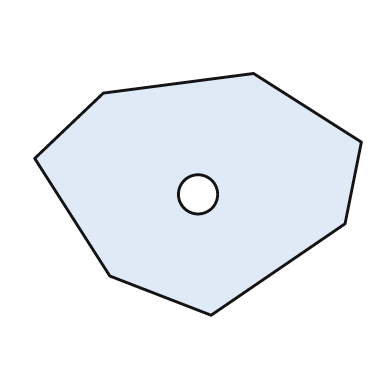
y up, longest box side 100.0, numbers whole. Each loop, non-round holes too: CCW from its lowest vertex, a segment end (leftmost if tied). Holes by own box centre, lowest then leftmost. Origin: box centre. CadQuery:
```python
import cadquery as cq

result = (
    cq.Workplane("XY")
    .moveTo(4.0, -37.0)
    .lineTo(45.0, -9.0)
    .lineTo(50.0, 16.0)
    .lineTo(17.0, 37.0)
    .lineTo(-29.0, 31.0)
    .lineTo(-50.0, 11.0)
    .lineTo(-27.0, -25.0)
    .close()
    .moveTo(0.0, 0.0)
    .circle(6.0)
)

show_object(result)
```